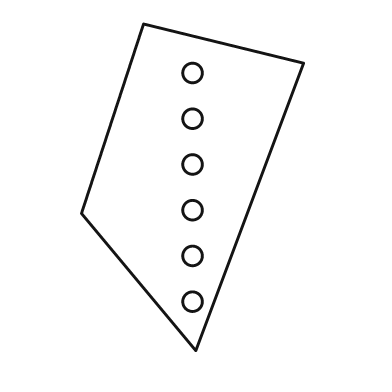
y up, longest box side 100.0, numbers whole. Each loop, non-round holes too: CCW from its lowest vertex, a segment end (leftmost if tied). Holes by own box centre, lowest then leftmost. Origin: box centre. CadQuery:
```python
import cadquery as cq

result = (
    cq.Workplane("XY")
    .moveTo(1.0, -50.0)
    .lineTo(34.0, 38.0)
    .lineTo(-15.0, 50.0)
    .lineTo(-34.0, -8.0)
    .close()
    .moveTo(0.0, -35.0)
    .circle(3.0)
    .moveTo(0.0, -21.0)
    .circle(3.0)
    .moveTo(0.0, -7.0)
    .circle(3.0)
    .moveTo(0.0, 7.0)
    .circle(3.0)
    .moveTo(0.0, 21.0)
    .circle(3.0)
    .moveTo(0.0, 35.0)
    .circle(3.0)
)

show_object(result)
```